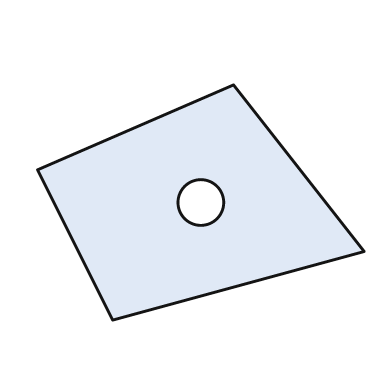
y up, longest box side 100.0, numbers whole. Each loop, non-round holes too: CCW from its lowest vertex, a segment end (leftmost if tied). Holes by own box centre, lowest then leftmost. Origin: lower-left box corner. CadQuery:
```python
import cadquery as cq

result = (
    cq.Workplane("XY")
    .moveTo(23.0, 0.0)
    .lineTo(100.0, 21.0)
    .lineTo(60.0, 72.0)
    .lineTo(0.0, 46.0)
    .close()
    .moveTo(50.0, 36.0)
    .circle(7.0)
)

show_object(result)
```